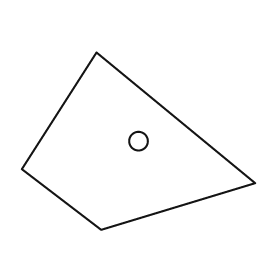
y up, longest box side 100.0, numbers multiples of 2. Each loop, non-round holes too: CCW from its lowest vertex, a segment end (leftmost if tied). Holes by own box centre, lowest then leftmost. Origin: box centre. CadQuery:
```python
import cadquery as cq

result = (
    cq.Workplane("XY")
    .moveTo(-16.0, -38.0)
    .lineTo(50.0, -18.0)
    .lineTo(-18.0, 38.0)
    .lineTo(-50.0, -12.0)
    .close()
    .moveTo(0.0, 0.0)
    .circle(4.0)
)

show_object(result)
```